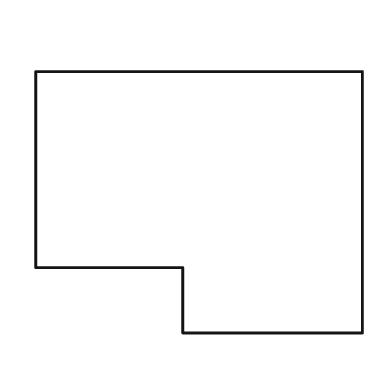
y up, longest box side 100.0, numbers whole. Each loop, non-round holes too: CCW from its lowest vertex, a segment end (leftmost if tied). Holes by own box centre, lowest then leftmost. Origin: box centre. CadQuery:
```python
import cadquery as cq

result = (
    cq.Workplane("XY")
    .moveTo(-5.0, -40.0)
    .lineTo(50.0, -40.0)
    .lineTo(50.0, 40.0)
    .lineTo(-50.0, 40.0)
    .lineTo(-50.0, -20.0)
    .lineTo(-5.0, -20.0)
    .close()
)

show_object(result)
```